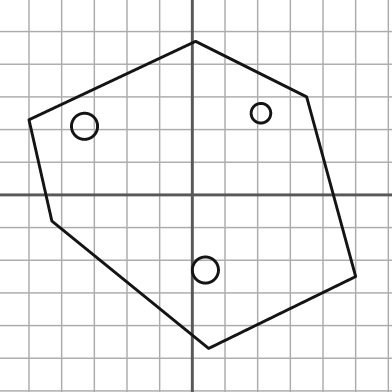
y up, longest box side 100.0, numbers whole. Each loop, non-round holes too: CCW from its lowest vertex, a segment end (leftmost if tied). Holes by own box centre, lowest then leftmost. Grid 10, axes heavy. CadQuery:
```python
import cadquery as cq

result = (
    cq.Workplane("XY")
    .moveTo(5.0, -47.0)
    .lineTo(50.0, -25.0)
    .lineTo(35.0, 30.0)
    .lineTo(1.0, 47.0)
    .lineTo(-50.0, 23.0)
    .lineTo(-43.0, -8.0)
    .close()
    .moveTo(4.0, -23.0)
    .circle(4.0)
    .moveTo(-33.0, 21.0)
    .circle(4.0)
    .moveTo(21.0, 25.0)
    .circle(3.0)
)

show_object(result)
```